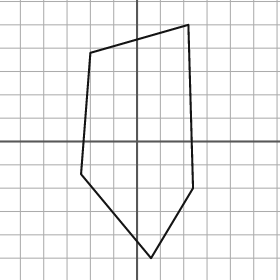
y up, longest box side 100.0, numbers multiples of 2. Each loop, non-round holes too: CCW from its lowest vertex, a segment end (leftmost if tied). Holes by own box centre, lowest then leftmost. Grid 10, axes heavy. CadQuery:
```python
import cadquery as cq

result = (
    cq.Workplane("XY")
    .moveTo(6.0, -50.0)
    .lineTo(24.0, -20.0)
    .lineTo(22.0, 50.0)
    .lineTo(-20.0, 38.0)
    .lineTo(-24.0, -14.0)
    .close()
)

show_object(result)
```